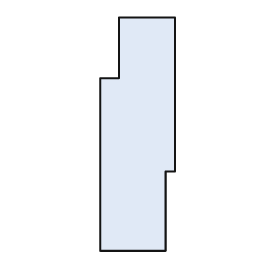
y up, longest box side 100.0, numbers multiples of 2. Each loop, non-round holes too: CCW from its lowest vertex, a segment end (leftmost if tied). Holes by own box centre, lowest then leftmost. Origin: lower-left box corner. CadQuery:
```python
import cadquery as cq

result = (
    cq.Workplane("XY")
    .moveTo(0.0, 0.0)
    .lineTo(28.0, 0.0)
    .lineTo(28.0, 34.0)
    .lineTo(32.0, 34.0)
    .lineTo(32.0, 100.0)
    .lineTo(8.0, 100.0)
    .lineTo(8.0, 74.0)
    .lineTo(0.0, 74.0)
    .close()
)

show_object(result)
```